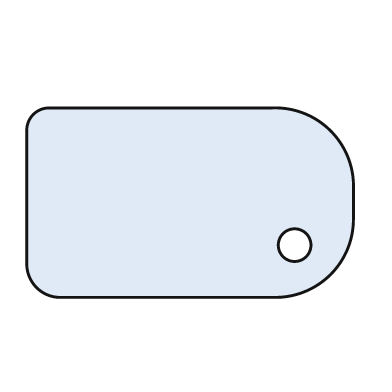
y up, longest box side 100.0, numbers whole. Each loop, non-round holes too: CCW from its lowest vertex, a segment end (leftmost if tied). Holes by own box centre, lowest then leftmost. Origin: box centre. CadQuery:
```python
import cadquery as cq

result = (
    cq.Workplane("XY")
    .moveTo(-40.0, -29.0)
    .lineTo(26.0, -29.0)
    .threePointArc((43.0, -22.0), (50.0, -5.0))
    .lineTo(50.0, 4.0)
    .threePointArc((43.0, 22.0), (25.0, 29.0))
    .lineTo(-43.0, 29.0)
    .threePointArc((-48.0, 27.0), (-50.0, 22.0))
    .lineTo(-50.0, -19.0)
    .threePointArc((-47.0, -26.0), (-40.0, -29.0))
    .close()
    .moveTo(32.0, -13.0)
    .circle(5.0)
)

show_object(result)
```